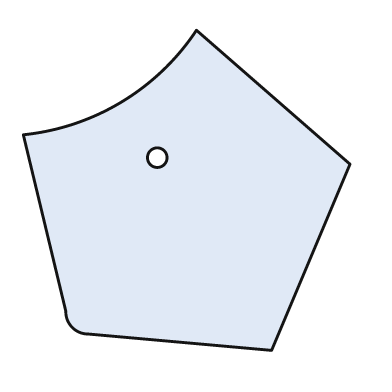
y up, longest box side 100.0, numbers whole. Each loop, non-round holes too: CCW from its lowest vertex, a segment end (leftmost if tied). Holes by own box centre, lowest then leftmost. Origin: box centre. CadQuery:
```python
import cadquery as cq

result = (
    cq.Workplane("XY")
    .moveTo(26.0, -49.0)
    .lineTo(50.0, 8.0)
    .lineTo(3.0, 49.0)
    .threePointArc((-20.0, 27.0), (-50.0, 17.0))
    .lineTo(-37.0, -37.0)
    .threePointArc((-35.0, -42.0), (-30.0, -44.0))
    .close()
    .moveTo(-9.0, 10.0)
    .circle(3.0)
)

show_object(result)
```